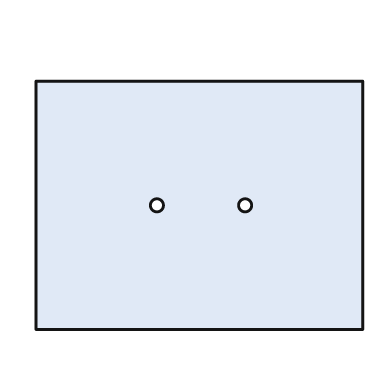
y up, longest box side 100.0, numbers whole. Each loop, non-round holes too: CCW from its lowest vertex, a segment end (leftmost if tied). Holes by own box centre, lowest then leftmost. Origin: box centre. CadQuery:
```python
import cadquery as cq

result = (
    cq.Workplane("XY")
    .moveTo(-50.0, -38.0)
    .lineTo(50.0, -38.0)
    .lineTo(50.0, 38.0)
    .lineTo(-50.0, 38.0)
    .close()
    .moveTo(-13.0, 0.0)
    .circle(2.0)
    .moveTo(14.0, 0.0)
    .circle(2.0)
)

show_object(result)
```